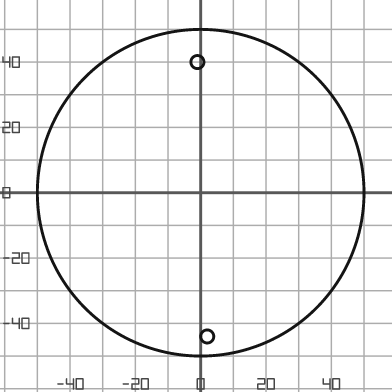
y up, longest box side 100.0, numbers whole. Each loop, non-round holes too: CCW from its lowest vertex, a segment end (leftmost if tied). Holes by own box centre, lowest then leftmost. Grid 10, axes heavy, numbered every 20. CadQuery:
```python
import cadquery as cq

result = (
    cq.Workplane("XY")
    .moveTo(0.0, 0.0)
    .circle(50.0)
    .moveTo(2.0, -44.0)
    .circle(2.0)
    .moveTo(-1.0, 40.0)
    .circle(2.0)
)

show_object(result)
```